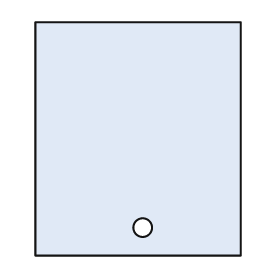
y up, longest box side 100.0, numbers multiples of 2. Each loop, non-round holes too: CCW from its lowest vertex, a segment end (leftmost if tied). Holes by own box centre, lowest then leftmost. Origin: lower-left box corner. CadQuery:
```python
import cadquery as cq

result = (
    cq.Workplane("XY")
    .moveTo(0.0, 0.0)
    .lineTo(88.0, 0.0)
    .lineTo(88.0, 100.0)
    .lineTo(0.0, 100.0)
    .close()
    .moveTo(46.0, 12.0)
    .circle(4.0)
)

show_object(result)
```